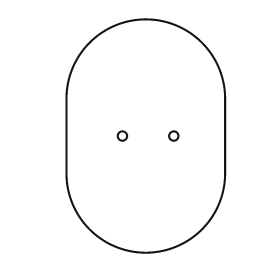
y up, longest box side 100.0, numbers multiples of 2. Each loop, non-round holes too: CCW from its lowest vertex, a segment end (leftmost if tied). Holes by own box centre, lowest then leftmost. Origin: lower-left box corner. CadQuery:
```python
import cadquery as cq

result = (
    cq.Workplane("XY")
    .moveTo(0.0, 34.0)
    .threePointArc((34.0, 0.0), (68.0, 34.0))
    .lineTo(68.0, 66.0)
    .threePointArc((34.0, 100.0), (0.0, 66.0))
    .close()
    .moveTo(24.0, 50.0)
    .circle(2.0)
    .moveTo(46.0, 50.0)
    .circle(2.0)
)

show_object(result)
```